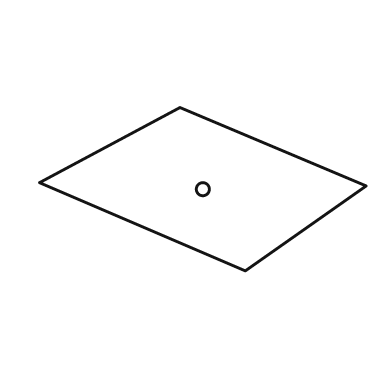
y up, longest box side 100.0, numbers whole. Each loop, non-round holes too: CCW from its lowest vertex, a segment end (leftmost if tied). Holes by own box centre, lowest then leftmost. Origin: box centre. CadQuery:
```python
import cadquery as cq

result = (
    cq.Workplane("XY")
    .moveTo(13.0, -25.0)
    .lineTo(50.0, 1.0)
    .lineTo(-7.0, 25.0)
    .lineTo(-50.0, 2.0)
    .close()
    .moveTo(0.0, 0.0)
    .circle(2.0)
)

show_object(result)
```